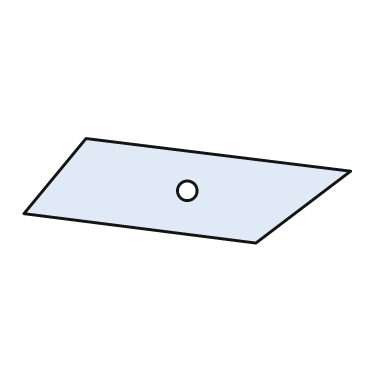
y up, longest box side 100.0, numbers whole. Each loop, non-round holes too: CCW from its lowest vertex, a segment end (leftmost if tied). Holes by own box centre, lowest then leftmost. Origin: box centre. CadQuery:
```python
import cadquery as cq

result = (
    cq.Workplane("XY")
    .moveTo(21.0, -16.0)
    .lineTo(50.0, 6.0)
    .lineTo(-31.0, 16.0)
    .lineTo(-50.0, -7.0)
    .close()
    .moveTo(0.0, 0.0)
    .circle(3.0)
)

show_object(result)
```